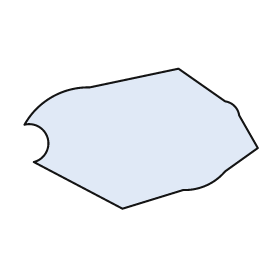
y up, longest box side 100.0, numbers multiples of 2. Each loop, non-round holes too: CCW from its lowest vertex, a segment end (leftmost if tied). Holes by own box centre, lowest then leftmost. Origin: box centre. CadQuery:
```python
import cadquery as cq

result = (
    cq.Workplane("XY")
    .moveTo(-8.0, -30.0)
    .lineTo(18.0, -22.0)
    .threePointArc((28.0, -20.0), (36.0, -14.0))
    .lineTo(50.0, -4.0)
    .lineTo(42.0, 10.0)
    .threePointArc((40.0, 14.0), (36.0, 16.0))
    .lineTo(16.0, 30.0)
    .lineTo(-22.0, 22.0)
    .threePointArc((-38.0, 18.0), (-50.0, 6.0))
    .threePointArc((-40.0, 0.0), (-46.0, -10.0))
    .close()
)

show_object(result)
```